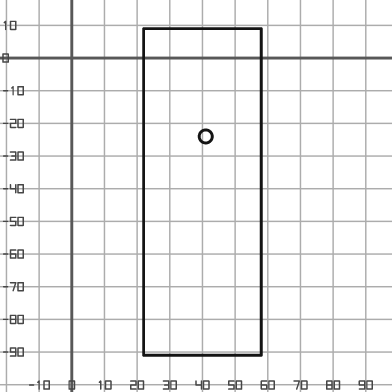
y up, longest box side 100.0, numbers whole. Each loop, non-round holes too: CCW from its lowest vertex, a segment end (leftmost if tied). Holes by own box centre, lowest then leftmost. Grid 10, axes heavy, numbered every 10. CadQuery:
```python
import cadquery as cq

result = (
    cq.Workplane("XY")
    .moveTo(22.0, -91.0)
    .lineTo(58.0, -91.0)
    .lineTo(58.0, 9.0)
    .lineTo(22.0, 9.0)
    .close()
    .moveTo(41.0, -24.0)
    .circle(2.0)
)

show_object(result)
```